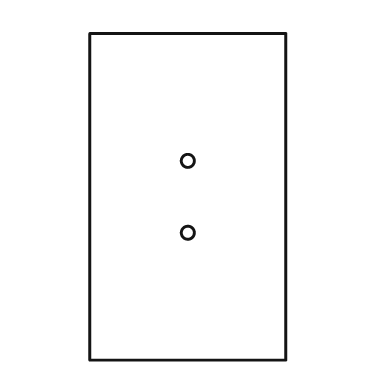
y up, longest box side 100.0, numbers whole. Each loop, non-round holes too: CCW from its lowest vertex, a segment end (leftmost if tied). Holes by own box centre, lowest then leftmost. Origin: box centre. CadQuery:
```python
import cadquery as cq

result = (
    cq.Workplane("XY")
    .moveTo(-30.0, -50.0)
    .lineTo(30.0, -50.0)
    .lineTo(30.0, 50.0)
    .lineTo(-30.0, 50.0)
    .close()
    .moveTo(0.0, -11.0)
    .circle(2.0)
    .moveTo(0.0, 11.0)
    .circle(2.0)
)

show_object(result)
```